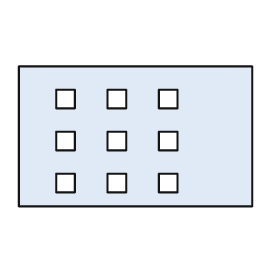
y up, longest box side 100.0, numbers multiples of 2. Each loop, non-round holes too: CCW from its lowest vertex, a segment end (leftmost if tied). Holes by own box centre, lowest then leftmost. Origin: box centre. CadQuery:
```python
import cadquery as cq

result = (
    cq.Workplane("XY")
    .moveTo(-50.0, -30.0)
    .lineTo(50.0, -30.0)
    .lineTo(50.0, 30.0)
    .lineTo(-50.0, 30.0)
    .close()
    .moveTo(-34.0, -24.0)
    .lineTo(-26.0, -24.0)
    .lineTo(-26.0, -16.0)
    .lineTo(-34.0, -16.0)
    .close()
    .moveTo(-12.0, -24.0)
    .lineTo(-4.0, -24.0)
    .lineTo(-4.0, -16.0)
    .lineTo(-12.0, -16.0)
    .close()
    .moveTo(10.0, -24.0)
    .lineTo(18.0, -24.0)
    .lineTo(18.0, -16.0)
    .lineTo(10.0, -16.0)
    .close()
    .moveTo(-34.0, -6.0)
    .lineTo(-26.0, -6.0)
    .lineTo(-26.0, 2.0)
    .lineTo(-34.0, 2.0)
    .close()
    .moveTo(-12.0, -6.0)
    .lineTo(-4.0, -6.0)
    .lineTo(-4.0, 2.0)
    .lineTo(-12.0, 2.0)
    .close()
    .moveTo(10.0, -6.0)
    .lineTo(18.0, -6.0)
    .lineTo(18.0, 2.0)
    .lineTo(10.0, 2.0)
    .close()
    .moveTo(-34.0, 12.0)
    .lineTo(-26.0, 12.0)
    .lineTo(-26.0, 20.0)
    .lineTo(-34.0, 20.0)
    .close()
    .moveTo(-12.0, 12.0)
    .lineTo(-4.0, 12.0)
    .lineTo(-4.0, 20.0)
    .lineTo(-12.0, 20.0)
    .close()
    .moveTo(10.0, 12.0)
    .lineTo(18.0, 12.0)
    .lineTo(18.0, 20.0)
    .lineTo(10.0, 20.0)
    .close()
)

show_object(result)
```